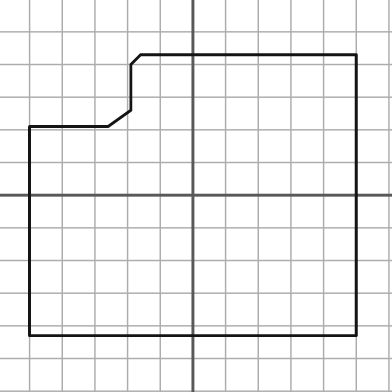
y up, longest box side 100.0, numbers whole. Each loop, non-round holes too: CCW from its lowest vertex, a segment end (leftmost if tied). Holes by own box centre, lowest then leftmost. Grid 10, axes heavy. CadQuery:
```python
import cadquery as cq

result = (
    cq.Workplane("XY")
    .moveTo(-50.0, -43.0)
    .lineTo(50.0, -43.0)
    .lineTo(50.0, 43.0)
    .lineTo(-16.0, 43.0)
    .lineTo(-19.0, 40.0)
    .lineTo(-19.0, 26.0)
    .lineTo(-26.0, 21.0)
    .lineTo(-50.0, 21.0)
    .close()
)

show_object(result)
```